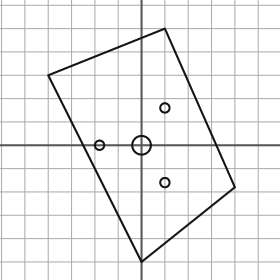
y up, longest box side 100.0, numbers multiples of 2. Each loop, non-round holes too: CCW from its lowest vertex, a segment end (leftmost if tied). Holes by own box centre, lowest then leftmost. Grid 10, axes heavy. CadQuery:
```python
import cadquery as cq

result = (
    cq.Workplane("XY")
    .moveTo(0.0, -50.0)
    .lineTo(40.0, -18.0)
    .lineTo(10.0, 50.0)
    .lineTo(-40.0, 30.0)
    .close()
    .moveTo(10.0, -16.0)
    .circle(2.0)
    .moveTo(-18.0, 0.0)
    .circle(2.0)
    .moveTo(0.0, 0.0)
    .circle(4.0)
    .moveTo(10.0, 16.0)
    .circle(2.0)
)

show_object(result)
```